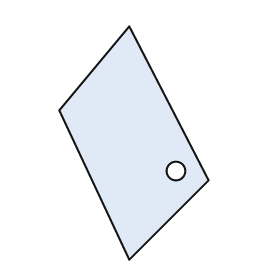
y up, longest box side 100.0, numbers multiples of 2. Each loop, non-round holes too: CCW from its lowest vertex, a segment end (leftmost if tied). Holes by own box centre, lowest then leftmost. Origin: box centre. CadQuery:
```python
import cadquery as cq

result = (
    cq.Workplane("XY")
    .moveTo(-2.0, -50.0)
    .lineTo(32.0, -16.0)
    .lineTo(-2.0, 50.0)
    .lineTo(-32.0, 14.0)
    .close()
    .moveTo(18.0, -12.0)
    .circle(4.0)
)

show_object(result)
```